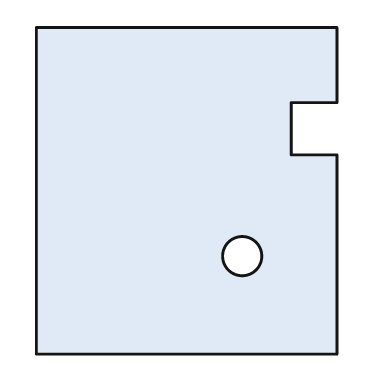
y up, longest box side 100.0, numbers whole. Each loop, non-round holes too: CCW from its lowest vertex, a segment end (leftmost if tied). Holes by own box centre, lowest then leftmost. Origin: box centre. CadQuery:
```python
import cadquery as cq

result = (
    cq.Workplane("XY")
    .moveTo(-46.0, -50.0)
    .lineTo(46.0, -50.0)
    .lineTo(46.0, 11.0)
    .lineTo(32.0, 11.0)
    .lineTo(32.0, 27.0)
    .lineTo(46.0, 27.0)
    .lineTo(46.0, 50.0)
    .lineTo(-46.0, 50.0)
    .close()
    .moveTo(17.0, -20.0)
    .circle(6.0)
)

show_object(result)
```